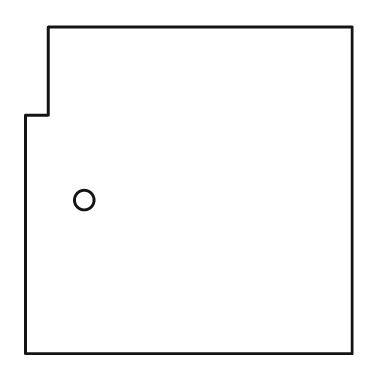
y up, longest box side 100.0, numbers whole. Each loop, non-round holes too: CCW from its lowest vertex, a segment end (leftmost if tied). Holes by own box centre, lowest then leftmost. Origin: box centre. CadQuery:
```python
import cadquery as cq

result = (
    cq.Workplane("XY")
    .moveTo(-50.0, -50.0)
    .lineTo(50.0, -50.0)
    .lineTo(50.0, 50.0)
    .lineTo(-43.0, 50.0)
    .lineTo(-43.0, 23.0)
    .lineTo(-50.0, 23.0)
    .close()
    .moveTo(-32.0, -3.0)
    .circle(3.0)
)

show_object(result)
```